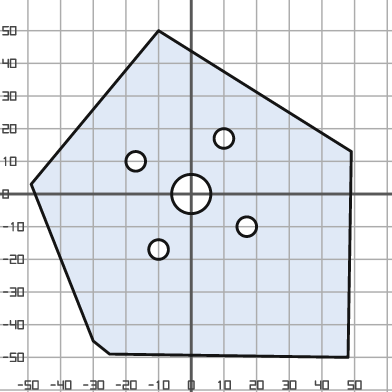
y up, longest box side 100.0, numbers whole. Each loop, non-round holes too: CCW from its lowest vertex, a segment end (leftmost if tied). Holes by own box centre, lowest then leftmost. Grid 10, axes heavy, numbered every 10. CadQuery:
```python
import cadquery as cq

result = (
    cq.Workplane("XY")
    .moveTo(48.0, -50.0)
    .lineTo(49.0, 13.0)
    .lineTo(-10.0, 50.0)
    .lineTo(-49.0, 3.0)
    .lineTo(-30.0, -45.0)
    .lineTo(-25.0, -49.0)
    .close()
    .moveTo(-10.0, -17.0)
    .circle(3.0)
    .moveTo(17.0, -10.0)
    .circle(3.0)
    .moveTo(0.0, 0.0)
    .circle(6.0)
    .moveTo(-17.0, 10.0)
    .circle(3.0)
    .moveTo(10.0, 17.0)
    .circle(3.0)
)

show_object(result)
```